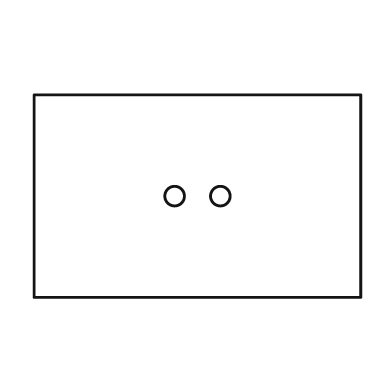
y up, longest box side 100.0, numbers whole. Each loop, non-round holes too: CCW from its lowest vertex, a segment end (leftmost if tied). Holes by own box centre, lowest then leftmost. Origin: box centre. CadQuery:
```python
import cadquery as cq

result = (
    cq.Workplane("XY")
    .moveTo(-50.0, -31.0)
    .lineTo(50.0, -31.0)
    .lineTo(50.0, 31.0)
    .lineTo(-50.0, 31.0)
    .close()
    .moveTo(-7.0, 0.0)
    .circle(3.0)
    .moveTo(7.0, 0.0)
    .circle(3.0)
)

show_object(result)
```